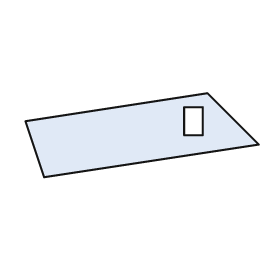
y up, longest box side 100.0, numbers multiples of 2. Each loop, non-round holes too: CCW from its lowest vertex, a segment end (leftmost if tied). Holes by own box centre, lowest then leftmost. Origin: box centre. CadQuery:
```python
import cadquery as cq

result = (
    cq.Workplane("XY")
    .moveTo(-42.0, -18.0)
    .lineTo(50.0, -4.0)
    .lineTo(28.0, 18.0)
    .lineTo(-50.0, 6.0)
    .close()
    .moveTo(18.0, 0.0)
    .lineTo(26.0, 0.0)
    .lineTo(26.0, 12.0)
    .lineTo(18.0, 12.0)
    .close()
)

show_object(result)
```